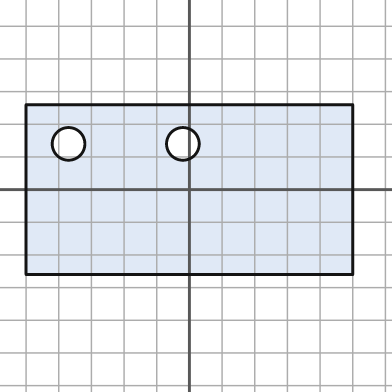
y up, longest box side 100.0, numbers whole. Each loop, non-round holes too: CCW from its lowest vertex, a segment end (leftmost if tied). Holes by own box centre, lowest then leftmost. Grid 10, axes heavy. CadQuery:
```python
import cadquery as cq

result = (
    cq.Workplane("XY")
    .moveTo(-50.0, -26.0)
    .lineTo(50.0, -26.0)
    .lineTo(50.0, 26.0)
    .lineTo(-50.0, 26.0)
    .close()
    .moveTo(-37.0, 14.0)
    .circle(5.0)
    .moveTo(-2.0, 14.0)
    .circle(5.0)
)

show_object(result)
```